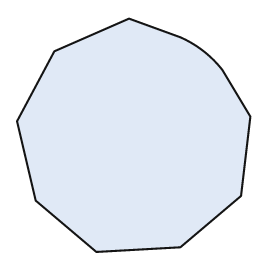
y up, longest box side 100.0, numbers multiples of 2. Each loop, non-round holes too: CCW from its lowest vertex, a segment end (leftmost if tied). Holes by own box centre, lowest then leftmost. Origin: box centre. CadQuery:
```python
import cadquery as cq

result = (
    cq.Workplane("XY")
    .moveTo(-16.0, -50.0)
    .lineTo(20.0, -48.0)
    .lineTo(46.0, -26.0)
    .lineTo(50.0, 8.0)
    .lineTo(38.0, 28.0)
    .threePointArc((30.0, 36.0), (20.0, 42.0))
    .lineTo(-2.0, 50.0)
    .lineTo(-34.0, 36.0)
    .lineTo(-50.0, 6.0)
    .lineTo(-42.0, -28.0)
    .close()
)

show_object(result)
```